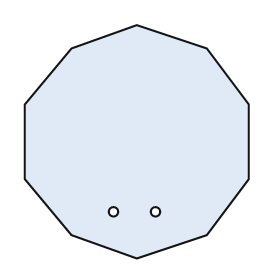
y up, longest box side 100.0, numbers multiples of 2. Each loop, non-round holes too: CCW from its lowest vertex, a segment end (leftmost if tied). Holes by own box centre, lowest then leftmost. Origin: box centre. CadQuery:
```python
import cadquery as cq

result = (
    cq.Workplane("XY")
    .moveTo(0.0, -50.0)
    .lineTo(30.0, -40.0)
    .lineTo(48.0, -16.0)
    .lineTo(48.0, 16.0)
    .lineTo(30.0, 40.0)
    .lineTo(0.0, 50.0)
    .lineTo(-28.0, 40.0)
    .lineTo(-48.0, 16.0)
    .lineTo(-48.0, -16.0)
    .lineTo(-28.0, -40.0)
    .close()
    .moveTo(-10.0, -30.0)
    .circle(2.0)
    .moveTo(8.0, -30.0)
    .circle(2.0)
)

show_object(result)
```